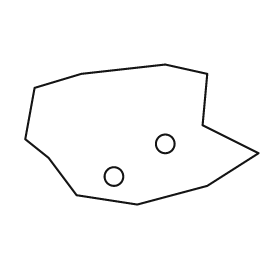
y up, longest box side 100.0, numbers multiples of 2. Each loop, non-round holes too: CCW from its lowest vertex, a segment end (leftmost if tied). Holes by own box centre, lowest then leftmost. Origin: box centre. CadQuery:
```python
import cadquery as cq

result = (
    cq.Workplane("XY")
    .moveTo(-2.0, -30.0)
    .lineTo(28.0, -22.0)
    .lineTo(50.0, -8.0)
    .lineTo(26.0, 4.0)
    .lineTo(28.0, 26.0)
    .lineTo(10.0, 30.0)
    .lineTo(-26.0, 26.0)
    .lineTo(-46.0, 20.0)
    .lineTo(-50.0, -2.0)
    .lineTo(-40.0, -10.0)
    .lineTo(-28.0, -26.0)
    .close()
    .moveTo(-12.0, -18.0)
    .circle(4.0)
    .moveTo(10.0, -4.0)
    .circle(4.0)
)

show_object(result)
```